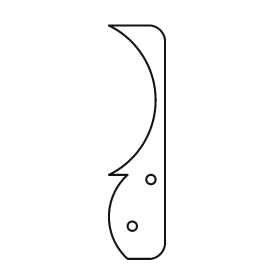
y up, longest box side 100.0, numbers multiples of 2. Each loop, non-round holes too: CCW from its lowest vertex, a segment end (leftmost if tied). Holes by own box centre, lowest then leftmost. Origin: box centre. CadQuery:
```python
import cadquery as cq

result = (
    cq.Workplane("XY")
    .moveTo(-4.0, -50.0)
    .lineTo(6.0, -50.0)
    .threePointArc((10.0, -48.0), (12.0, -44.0))
    .lineTo(12.0, 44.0)
    .threePointArc((10.0, 48.0), (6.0, 50.0))
    .lineTo(-12.0, 50.0)
    .threePointArc((8.0, 18.0), (-12.0, -14.0))
    .lineTo(-4.0, -14.0)
    .threePointArc((-12.0, -32.0), (-4.0, -50.0))
    .close()
    .moveTo(-2.0, -36.0)
    .circle(2.0)
    .moveTo(6.0, -16.0)
    .circle(2.0)
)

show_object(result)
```